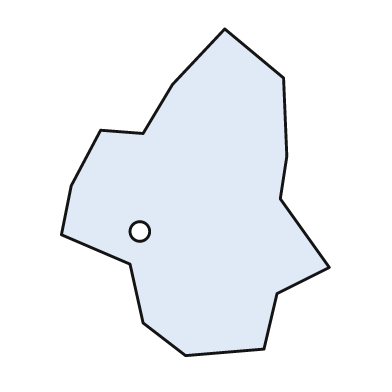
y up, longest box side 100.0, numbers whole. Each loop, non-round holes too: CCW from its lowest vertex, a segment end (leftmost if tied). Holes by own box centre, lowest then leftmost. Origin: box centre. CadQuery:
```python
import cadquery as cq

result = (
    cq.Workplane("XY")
    .moveTo(-3.0, -50.0)
    .lineTo(21.0, -48.0)
    .lineTo(25.0, -31.0)
    .lineTo(41.0, -23.0)
    .lineTo(26.0, -2.0)
    .lineTo(28.0, 11.0)
    .lineTo(27.0, 35.0)
    .lineTo(9.0, 50.0)
    .lineTo(-7.0, 33.0)
    .lineTo(-16.0, 18.0)
    .lineTo(-29.0, 19.0)
    .lineTo(-38.0, 2.0)
    .lineTo(-41.0, -13.0)
    .lineTo(-20.0, -22.0)
    .lineTo(-16.0, -40.0)
    .close()
    .moveTo(-17.0, -12.0)
    .circle(3.0)
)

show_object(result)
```